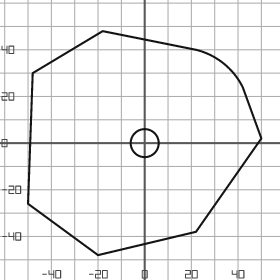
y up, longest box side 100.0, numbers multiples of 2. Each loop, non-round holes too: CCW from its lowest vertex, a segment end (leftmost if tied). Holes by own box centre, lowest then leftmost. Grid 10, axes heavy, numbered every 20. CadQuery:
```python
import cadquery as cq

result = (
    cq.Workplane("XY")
    .moveTo(-20.0, -48.0)
    .lineTo(22.0, -38.0)
    .lineTo(50.0, 2.0)
    .lineTo(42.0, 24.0)
    .threePointArc((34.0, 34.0), (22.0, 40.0))
    .lineTo(-18.0, 48.0)
    .lineTo(-48.0, 30.0)
    .lineTo(-50.0, -26.0)
    .close()
    .moveTo(0.0, 0.0)
    .circle(6.0)
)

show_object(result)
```